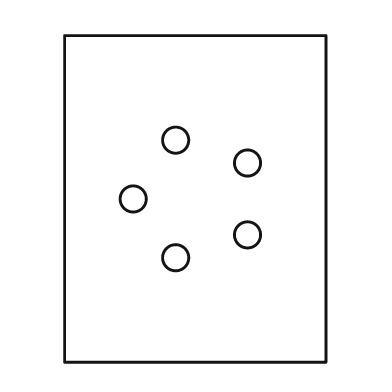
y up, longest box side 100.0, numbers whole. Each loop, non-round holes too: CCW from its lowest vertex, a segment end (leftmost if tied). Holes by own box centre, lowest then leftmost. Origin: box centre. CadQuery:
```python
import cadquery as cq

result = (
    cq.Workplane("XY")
    .moveTo(-40.0, -50.0)
    .lineTo(40.0, -50.0)
    .lineTo(40.0, 50.0)
    .lineTo(-40.0, 50.0)
    .close()
    .moveTo(-6.0, -18.0)
    .circle(4.0)
    .moveTo(16.0, -11.0)
    .circle(4.0)
    .moveTo(-19.0, 0.0)
    .circle(4.0)
    .moveTo(16.0, 11.0)
    .circle(4.0)
    .moveTo(-6.0, 18.0)
    .circle(4.0)
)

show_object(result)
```